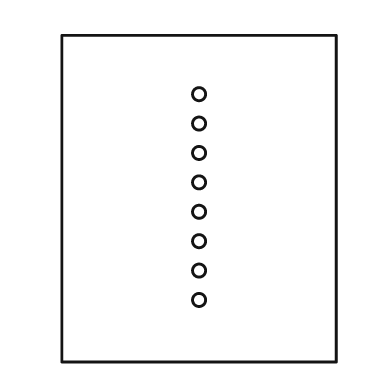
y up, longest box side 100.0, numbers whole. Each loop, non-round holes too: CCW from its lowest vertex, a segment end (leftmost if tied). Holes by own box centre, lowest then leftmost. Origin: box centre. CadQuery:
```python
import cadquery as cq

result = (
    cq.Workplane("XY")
    .moveTo(-42.0, -50.0)
    .lineTo(42.0, -50.0)
    .lineTo(42.0, 50.0)
    .lineTo(-42.0, 50.0)
    .close()
    .moveTo(0.0, -31.0)
    .circle(2.0)
    .moveTo(0.0, -22.0)
    .circle(2.0)
    .moveTo(0.0, -13.0)
    .circle(2.0)
    .moveTo(0.0, -4.0)
    .circle(2.0)
    .moveTo(0.0, 5.0)
    .circle(2.0)
    .moveTo(0.0, 14.0)
    .circle(2.0)
    .moveTo(0.0, 23.0)
    .circle(2.0)
    .moveTo(0.0, 32.0)
    .circle(2.0)
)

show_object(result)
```